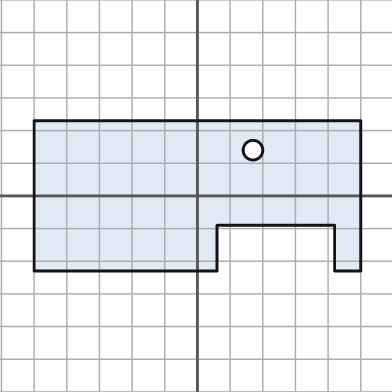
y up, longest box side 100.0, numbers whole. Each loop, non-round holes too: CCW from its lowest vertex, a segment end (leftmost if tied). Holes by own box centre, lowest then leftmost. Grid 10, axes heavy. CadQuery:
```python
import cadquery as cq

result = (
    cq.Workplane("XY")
    .moveTo(-50.0, -23.0)
    .lineTo(6.0, -23.0)
    .lineTo(6.0, -9.0)
    .lineTo(42.0, -9.0)
    .lineTo(42.0, -23.0)
    .lineTo(50.0, -23.0)
    .lineTo(50.0, 23.0)
    .lineTo(-50.0, 23.0)
    .close()
    .moveTo(17.0, 14.0)
    .circle(3.0)
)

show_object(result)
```